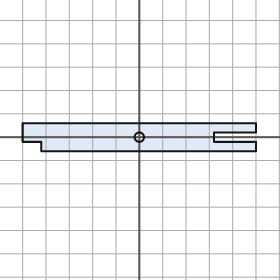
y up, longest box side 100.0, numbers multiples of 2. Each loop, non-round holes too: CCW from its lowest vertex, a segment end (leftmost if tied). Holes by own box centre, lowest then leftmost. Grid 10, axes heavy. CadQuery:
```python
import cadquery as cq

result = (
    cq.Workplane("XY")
    .moveTo(-42.0, -6.0)
    .lineTo(50.0, -6.0)
    .lineTo(50.0, -2.0)
    .lineTo(32.0, -2.0)
    .lineTo(32.0, 2.0)
    .lineTo(50.0, 2.0)
    .lineTo(50.0, 6.0)
    .lineTo(-50.0, 6.0)
    .lineTo(-50.0, -2.0)
    .lineTo(-42.0, -2.0)
    .close()
    .moveTo(0.0, 0.0)
    .circle(2.0)
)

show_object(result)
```